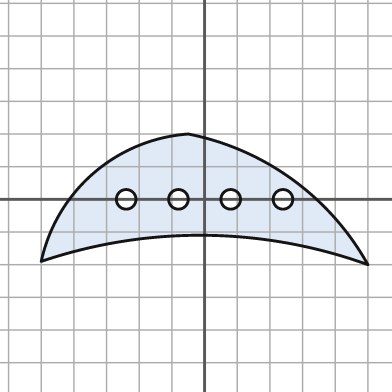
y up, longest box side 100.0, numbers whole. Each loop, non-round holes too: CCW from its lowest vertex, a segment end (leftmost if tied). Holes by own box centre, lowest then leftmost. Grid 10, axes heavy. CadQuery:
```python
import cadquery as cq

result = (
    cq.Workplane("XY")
    .moveTo(50.0, -20.0)
    .threePointArc((27.0, 6.0), (-5.0, 20.0))
    .threePointArc((-34.0, 8.0), (-50.0, -19.0))
    .threePointArc((0.0, -11.0), (50.0, -20.0))
    .close()
    .moveTo(-24.0, 0.0)
    .circle(3.0)
    .moveTo(-8.0, 0.0)
    .circle(3.0)
    .moveTo(8.0, 0.0)
    .circle(3.0)
    .moveTo(24.0, 0.0)
    .circle(3.0)
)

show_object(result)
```